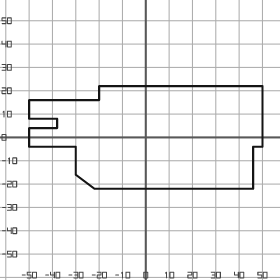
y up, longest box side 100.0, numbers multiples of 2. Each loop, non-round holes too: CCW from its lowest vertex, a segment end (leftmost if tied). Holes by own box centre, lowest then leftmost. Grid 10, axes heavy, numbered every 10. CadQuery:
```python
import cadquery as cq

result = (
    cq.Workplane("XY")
    .moveTo(-22.0, -22.0)
    .lineTo(46.0, -22.0)
    .lineTo(46.0, -4.0)
    .lineTo(50.0, -4.0)
    .lineTo(50.0, 22.0)
    .lineTo(-20.0, 22.0)
    .lineTo(-20.0, 16.0)
    .lineTo(-50.0, 16.0)
    .lineTo(-50.0, 8.0)
    .lineTo(-38.0, 8.0)
    .lineTo(-38.0, 4.0)
    .lineTo(-50.0, 4.0)
    .lineTo(-50.0, -4.0)
    .lineTo(-30.0, -4.0)
    .lineTo(-30.0, -16.0)
    .close()
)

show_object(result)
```